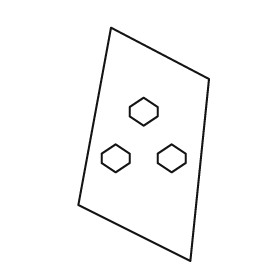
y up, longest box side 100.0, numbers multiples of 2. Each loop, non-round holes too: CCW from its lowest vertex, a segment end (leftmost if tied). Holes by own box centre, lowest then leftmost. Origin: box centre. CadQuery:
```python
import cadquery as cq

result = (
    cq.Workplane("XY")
    .moveTo(20.0, -50.0)
    .lineTo(28.0, 28.0)
    .lineTo(-14.0, 50.0)
    .lineTo(-28.0, -26.0)
    .close()
    .moveTo(-12.0, -12.0)
    .lineTo(-6.0, -8.0)
    .lineTo(-6.0, -4.0)
    .lineTo(-12.0, 0.0)
    .lineTo(-18.0, -4.0)
    .lineTo(-18.0, -8.0)
    .close()
    .moveTo(12.0, -12.0)
    .lineTo(18.0, -8.0)
    .lineTo(18.0, -4.0)
    .lineTo(12.0, 0.0)
    .lineTo(6.0, -4.0)
    .lineTo(6.0, -8.0)
    .close()
    .moveTo(0.0, 8.0)
    .lineTo(6.0, 12.0)
    .lineTo(6.0, 16.0)
    .lineTo(0.0, 20.0)
    .lineTo(-6.0, 16.0)
    .lineTo(-6.0, 12.0)
    .close()
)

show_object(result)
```